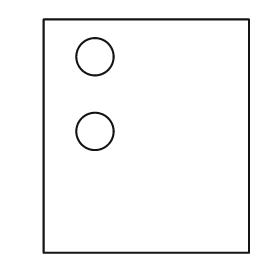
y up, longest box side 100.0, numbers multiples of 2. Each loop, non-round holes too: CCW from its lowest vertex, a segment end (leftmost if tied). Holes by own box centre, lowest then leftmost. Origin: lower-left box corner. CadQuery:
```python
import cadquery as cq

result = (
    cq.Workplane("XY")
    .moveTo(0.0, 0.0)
    .lineTo(88.0, 0.0)
    .lineTo(88.0, 100.0)
    .lineTo(0.0, 100.0)
    .close()
    .moveTo(22.0, 52.0)
    .circle(8.0)
    .moveTo(22.0, 84.0)
    .circle(8.0)
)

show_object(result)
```